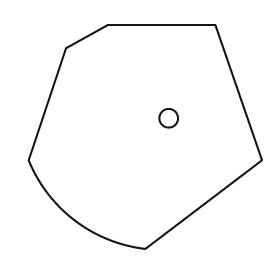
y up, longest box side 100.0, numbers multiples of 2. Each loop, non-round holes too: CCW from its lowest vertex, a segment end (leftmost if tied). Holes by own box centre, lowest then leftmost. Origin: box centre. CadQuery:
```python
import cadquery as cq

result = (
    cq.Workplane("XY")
    .moveTo(0.0, -48.0)
    .lineTo(50.0, -10.0)
    .lineTo(30.0, 48.0)
    .lineTo(-16.0, 48.0)
    .lineTo(-34.0, 38.0)
    .lineTo(-50.0, -10.0)
    .threePointArc((-30.0, -36.0), (0.0, -48.0))
    .close()
    .moveTo(10.0, 8.0)
    .circle(4.0)
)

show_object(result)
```